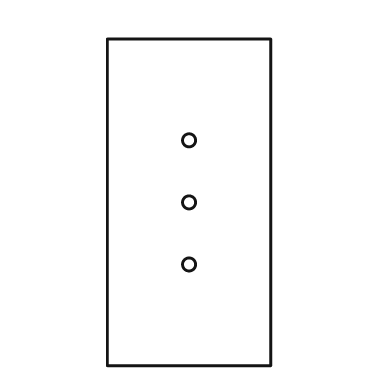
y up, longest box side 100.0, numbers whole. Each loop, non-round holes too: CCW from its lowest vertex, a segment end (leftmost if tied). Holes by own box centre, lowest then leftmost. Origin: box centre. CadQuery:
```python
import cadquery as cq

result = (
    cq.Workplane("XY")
    .moveTo(-25.0, -50.0)
    .lineTo(25.0, -50.0)
    .lineTo(25.0, 50.0)
    .lineTo(-25.0, 50.0)
    .close()
    .moveTo(0.0, -19.0)
    .circle(2.0)
    .moveTo(0.0, 0.0)
    .circle(2.0)
    .moveTo(0.0, 19.0)
    .circle(2.0)
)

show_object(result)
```